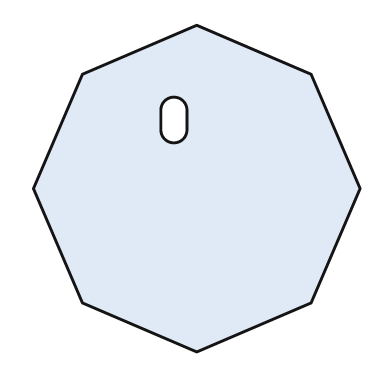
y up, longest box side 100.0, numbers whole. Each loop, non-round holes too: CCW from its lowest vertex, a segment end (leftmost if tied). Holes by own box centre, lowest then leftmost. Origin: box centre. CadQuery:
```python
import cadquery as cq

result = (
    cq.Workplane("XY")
    .moveTo(0.0, -50.0)
    .lineTo(35.0, -35.0)
    .lineTo(50.0, 0.0)
    .lineTo(35.0, 35.0)
    .lineTo(0.0, 50.0)
    .lineTo(-35.0, 35.0)
    .lineTo(-50.0, 0.0)
    .lineTo(-35.0, -35.0)
    .close()
    .moveTo(-11.0, 18.0)
    .threePointArc((-7.0, 14.0), (-3.0, 18.0))
    .lineTo(-3.0, 24.0)
    .threePointArc((-7.0, 28.0), (-11.0, 24.0))
    .close()
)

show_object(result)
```